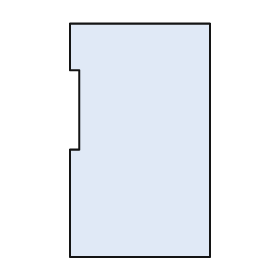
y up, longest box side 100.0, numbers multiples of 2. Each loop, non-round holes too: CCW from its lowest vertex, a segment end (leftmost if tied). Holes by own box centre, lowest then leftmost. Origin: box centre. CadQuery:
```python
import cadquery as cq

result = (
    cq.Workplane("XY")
    .moveTo(-30.0, -50.0)
    .lineTo(30.0, -50.0)
    .lineTo(30.0, 50.0)
    .lineTo(-30.0, 50.0)
    .lineTo(-30.0, 30.0)
    .lineTo(-26.0, 30.0)
    .lineTo(-26.0, -4.0)
    .lineTo(-30.0, -4.0)
    .close()
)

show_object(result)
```